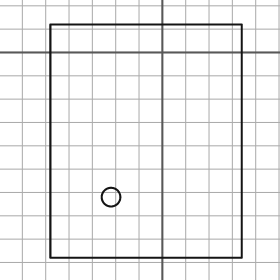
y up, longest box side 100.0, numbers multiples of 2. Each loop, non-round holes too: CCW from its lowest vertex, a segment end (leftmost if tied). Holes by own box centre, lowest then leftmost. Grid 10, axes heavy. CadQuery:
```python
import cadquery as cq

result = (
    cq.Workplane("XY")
    .moveTo(-48.0, -88.0)
    .lineTo(34.0, -88.0)
    .lineTo(34.0, 12.0)
    .lineTo(-48.0, 12.0)
    .close()
    .moveTo(-22.0, -62.0)
    .circle(4.0)
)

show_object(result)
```